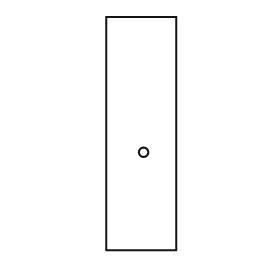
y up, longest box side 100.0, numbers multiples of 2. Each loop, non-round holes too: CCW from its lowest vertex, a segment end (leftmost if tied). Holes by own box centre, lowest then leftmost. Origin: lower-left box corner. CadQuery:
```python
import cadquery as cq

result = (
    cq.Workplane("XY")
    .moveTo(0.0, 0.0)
    .lineTo(30.0, 0.0)
    .lineTo(30.0, 100.0)
    .lineTo(0.0, 100.0)
    .close()
    .moveTo(16.0, 42.0)
    .circle(2.0)
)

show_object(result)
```